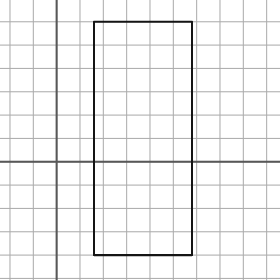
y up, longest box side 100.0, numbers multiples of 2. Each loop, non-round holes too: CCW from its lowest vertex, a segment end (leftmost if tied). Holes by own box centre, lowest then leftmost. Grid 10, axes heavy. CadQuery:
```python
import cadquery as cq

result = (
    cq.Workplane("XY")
    .moveTo(16.0, -40.0)
    .lineTo(58.0, -40.0)
    .lineTo(58.0, 60.0)
    .lineTo(16.0, 60.0)
    .close()
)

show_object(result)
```